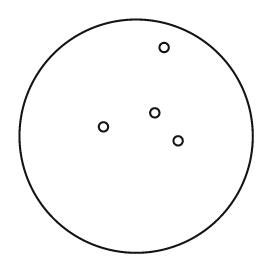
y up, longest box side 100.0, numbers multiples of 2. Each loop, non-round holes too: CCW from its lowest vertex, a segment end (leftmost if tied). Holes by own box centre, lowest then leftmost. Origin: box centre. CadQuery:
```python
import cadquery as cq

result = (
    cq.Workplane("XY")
    .moveTo(0.0, 0.0)
    .circle(50.0)
    .moveTo(18.0, -2.0)
    .circle(2.0)
    .moveTo(-14.0, 4.0)
    .circle(2.0)
    .moveTo(8.0, 10.0)
    .circle(2.0)
    .moveTo(12.0, 38.0)
    .circle(2.0)
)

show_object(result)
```